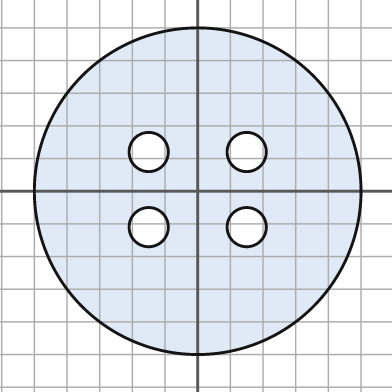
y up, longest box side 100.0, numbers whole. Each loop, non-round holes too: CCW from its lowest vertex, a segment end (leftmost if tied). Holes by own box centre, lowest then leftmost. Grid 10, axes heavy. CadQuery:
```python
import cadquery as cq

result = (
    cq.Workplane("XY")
    .moveTo(0.0, 0.0)
    .circle(50.0)
    .moveTo(-15.0, -11.0)
    .circle(6.0)
    .moveTo(15.0, -11.0)
    .circle(6.0)
    .moveTo(-15.0, 12.0)
    .circle(6.0)
    .moveTo(15.0, 12.0)
    .circle(6.0)
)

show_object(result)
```